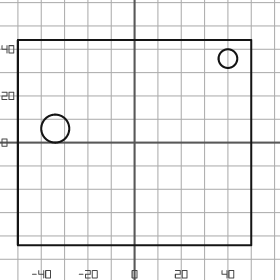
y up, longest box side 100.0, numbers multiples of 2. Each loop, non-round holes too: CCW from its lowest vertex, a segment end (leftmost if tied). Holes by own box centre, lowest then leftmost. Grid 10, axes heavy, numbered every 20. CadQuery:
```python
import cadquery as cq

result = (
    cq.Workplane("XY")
    .moveTo(-50.0, -44.0)
    .lineTo(50.0, -44.0)
    .lineTo(50.0, 44.0)
    .lineTo(-50.0, 44.0)
    .close()
    .moveTo(-34.0, 6.0)
    .circle(6.0)
    .moveTo(40.0, 36.0)
    .circle(4.0)
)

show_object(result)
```